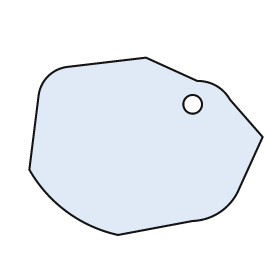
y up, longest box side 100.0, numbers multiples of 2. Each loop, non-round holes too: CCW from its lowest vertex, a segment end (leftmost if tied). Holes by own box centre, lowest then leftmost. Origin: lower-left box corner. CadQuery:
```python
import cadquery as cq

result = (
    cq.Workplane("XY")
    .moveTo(38.0, 0.0)
    .lineTo(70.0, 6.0)
    .threePointArc((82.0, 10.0), (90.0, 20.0))
    .lineTo(100.0, 42.0)
    .lineTo(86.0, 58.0)
    .threePointArc((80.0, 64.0), (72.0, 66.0))
    .lineTo(50.0, 76.0)
    .lineTo(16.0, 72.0)
    .threePointArc((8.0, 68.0), (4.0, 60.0))
    .lineTo(0.0, 28.0)
    .threePointArc((16.0, 10.0), (38.0, 0.0))
    .close()
    .moveTo(70.0, 56.0)
    .circle(4.0)
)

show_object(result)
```